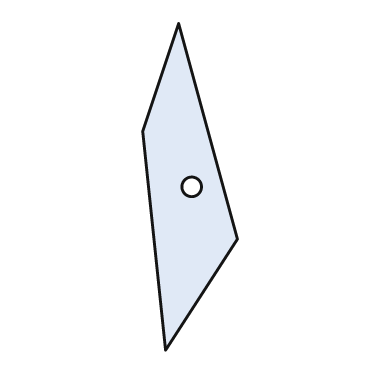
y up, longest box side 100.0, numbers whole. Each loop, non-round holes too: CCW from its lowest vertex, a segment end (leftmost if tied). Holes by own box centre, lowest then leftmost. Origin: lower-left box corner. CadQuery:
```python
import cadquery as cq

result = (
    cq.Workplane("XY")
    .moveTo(7.0, 0.0)
    .lineTo(29.0, 34.0)
    .lineTo(11.0, 100.0)
    .lineTo(0.0, 67.0)
    .close()
    .moveTo(15.0, 50.0)
    .circle(3.0)
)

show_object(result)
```